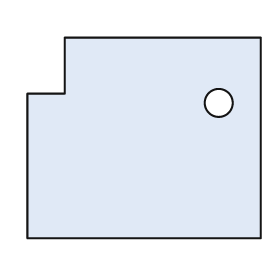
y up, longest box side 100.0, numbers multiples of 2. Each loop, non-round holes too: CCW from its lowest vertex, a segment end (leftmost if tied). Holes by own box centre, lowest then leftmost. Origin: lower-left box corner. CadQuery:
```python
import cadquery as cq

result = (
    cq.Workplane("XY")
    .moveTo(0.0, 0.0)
    .lineTo(100.0, 0.0)
    .lineTo(100.0, 86.0)
    .lineTo(16.0, 86.0)
    .lineTo(16.0, 62.0)
    .lineTo(0.0, 62.0)
    .close()
    .moveTo(82.0, 58.0)
    .circle(6.0)
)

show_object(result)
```